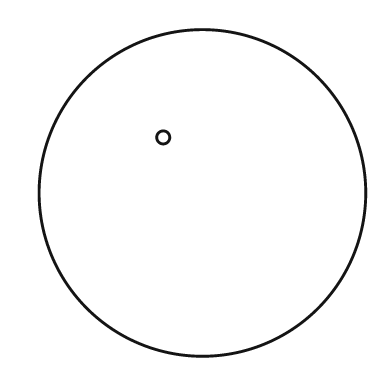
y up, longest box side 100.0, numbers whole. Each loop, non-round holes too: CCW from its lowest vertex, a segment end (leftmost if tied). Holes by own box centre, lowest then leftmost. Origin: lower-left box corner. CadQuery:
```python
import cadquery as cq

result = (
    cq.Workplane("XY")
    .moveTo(50.0, 50.0)
    .circle(50.0)
    .moveTo(38.0, 67.0)
    .circle(2.0)
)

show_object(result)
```